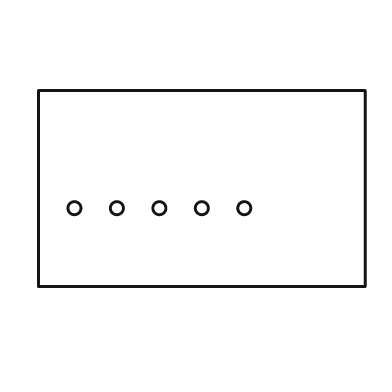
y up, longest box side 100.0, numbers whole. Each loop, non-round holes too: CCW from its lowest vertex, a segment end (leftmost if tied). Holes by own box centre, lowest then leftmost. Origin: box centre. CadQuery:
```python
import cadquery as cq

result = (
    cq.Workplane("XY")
    .moveTo(-50.0, -30.0)
    .lineTo(50.0, -30.0)
    .lineTo(50.0, 30.0)
    .lineTo(-50.0, 30.0)
    .close()
    .moveTo(-39.0, -6.0)
    .circle(2.0)
    .moveTo(-26.0, -6.0)
    .circle(2.0)
    .moveTo(-13.0, -6.0)
    .circle(2.0)
    .moveTo(0.0, -6.0)
    .circle(2.0)
    .moveTo(13.0, -6.0)
    .circle(2.0)
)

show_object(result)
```